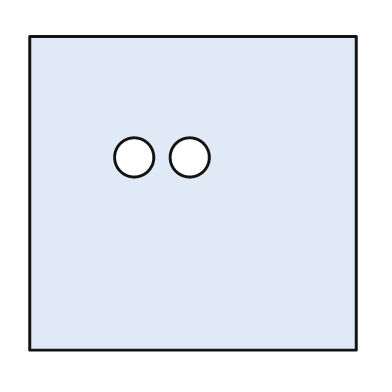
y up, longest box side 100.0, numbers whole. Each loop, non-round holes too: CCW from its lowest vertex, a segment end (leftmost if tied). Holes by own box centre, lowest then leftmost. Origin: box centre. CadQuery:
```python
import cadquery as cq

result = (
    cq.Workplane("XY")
    .moveTo(-50.0, -48.0)
    .lineTo(50.0, -48.0)
    .lineTo(50.0, 48.0)
    .lineTo(-50.0, 48.0)
    .close()
    .moveTo(-18.0, 11.0)
    .circle(6.0)
    .moveTo(-1.0, 11.0)
    .circle(6.0)
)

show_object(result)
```